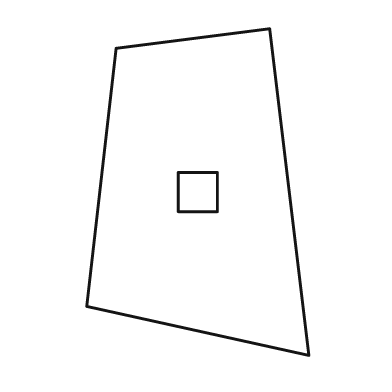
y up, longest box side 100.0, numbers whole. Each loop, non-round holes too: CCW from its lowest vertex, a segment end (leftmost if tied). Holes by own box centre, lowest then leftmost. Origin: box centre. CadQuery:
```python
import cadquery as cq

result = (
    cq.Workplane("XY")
    .moveTo(34.0, -50.0)
    .lineTo(22.0, 50.0)
    .lineTo(-25.0, 44.0)
    .lineTo(-34.0, -35.0)
    .close()
    .moveTo(-6.0, -6.0)
    .lineTo(6.0, -6.0)
    .lineTo(6.0, 6.0)
    .lineTo(-6.0, 6.0)
    .close()
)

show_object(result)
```